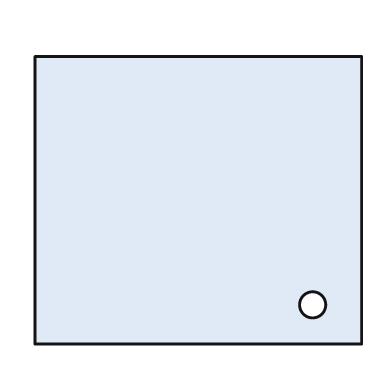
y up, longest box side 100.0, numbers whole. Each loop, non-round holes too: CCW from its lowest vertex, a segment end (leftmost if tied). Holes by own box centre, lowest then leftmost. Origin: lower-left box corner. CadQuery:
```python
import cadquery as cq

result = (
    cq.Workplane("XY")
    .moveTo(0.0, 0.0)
    .lineTo(100.0, 0.0)
    .lineTo(100.0, 88.0)
    .lineTo(0.0, 88.0)
    .close()
    .moveTo(85.0, 12.0)
    .circle(4.0)
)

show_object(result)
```